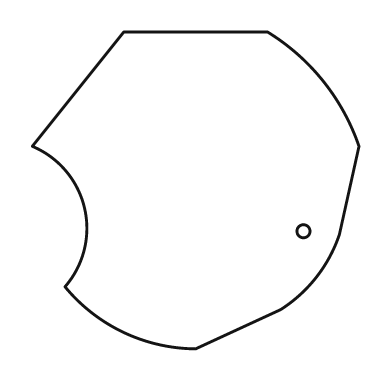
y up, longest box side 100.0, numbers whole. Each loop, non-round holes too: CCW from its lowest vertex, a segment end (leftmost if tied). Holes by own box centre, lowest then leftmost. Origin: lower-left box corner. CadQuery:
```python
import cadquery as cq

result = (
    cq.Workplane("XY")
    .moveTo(50.0, 0.0)
    .lineTo(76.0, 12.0)
    .threePointArc((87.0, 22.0), (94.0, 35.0))
    .lineTo(100.0, 62.0)
    .threePointArc((89.0, 82.0), (72.0, 97.0))
    .lineTo(28.0, 97.0)
    .lineTo(0.0, 62.0)
    .threePointArc((16.0, 43.0), (10.0, 19.0))
    .threePointArc((28.0, 5.0), (50.0, 0.0))
    .close()
    .moveTo(83.0, 36.0)
    .circle(2.0)
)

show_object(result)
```